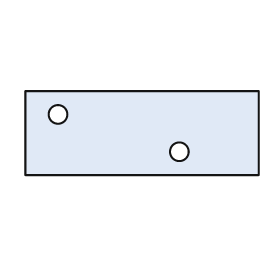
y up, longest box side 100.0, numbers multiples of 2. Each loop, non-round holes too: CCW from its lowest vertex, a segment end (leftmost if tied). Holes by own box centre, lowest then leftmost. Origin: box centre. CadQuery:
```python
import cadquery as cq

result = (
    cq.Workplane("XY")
    .moveTo(-50.0, -18.0)
    .lineTo(50.0, -18.0)
    .lineTo(50.0, 18.0)
    .lineTo(-50.0, 18.0)
    .close()
    .moveTo(16.0, -8.0)
    .circle(4.0)
    .moveTo(-36.0, 8.0)
    .circle(4.0)
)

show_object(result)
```